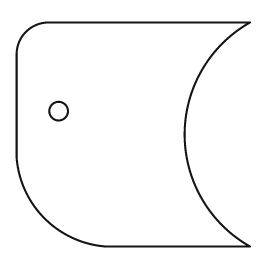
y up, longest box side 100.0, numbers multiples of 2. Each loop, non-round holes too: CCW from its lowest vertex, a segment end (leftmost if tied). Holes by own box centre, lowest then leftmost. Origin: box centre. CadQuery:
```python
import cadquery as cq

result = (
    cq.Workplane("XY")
    .moveTo(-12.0, -48.0)
    .lineTo(50.0, -48.0)
    .threePointArc((22.0, 0.0), (50.0, 48.0))
    .lineTo(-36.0, 48.0)
    .threePointArc((-46.0, 44.0), (-50.0, 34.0))
    .lineTo(-50.0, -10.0)
    .threePointArc((-38.0, -36.0), (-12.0, -48.0))
    .close()
    .moveTo(-32.0, 10.0)
    .circle(4.0)
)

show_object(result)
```